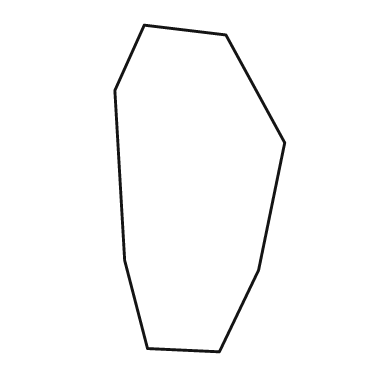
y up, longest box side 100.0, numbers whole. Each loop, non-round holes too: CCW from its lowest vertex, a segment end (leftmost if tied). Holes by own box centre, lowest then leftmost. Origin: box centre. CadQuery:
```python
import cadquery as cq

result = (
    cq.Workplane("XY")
    .moveTo(6.0, -50.0)
    .lineTo(18.0, -25.0)
    .lineTo(26.0, 14.0)
    .lineTo(8.0, 47.0)
    .lineTo(-17.0, 50.0)
    .lineTo(-26.0, 30.0)
    .lineTo(-23.0, -22.0)
    .lineTo(-16.0, -49.0)
    .close()
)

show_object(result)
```